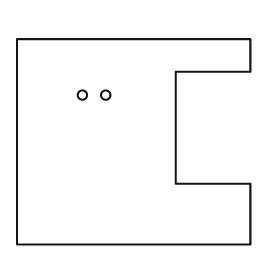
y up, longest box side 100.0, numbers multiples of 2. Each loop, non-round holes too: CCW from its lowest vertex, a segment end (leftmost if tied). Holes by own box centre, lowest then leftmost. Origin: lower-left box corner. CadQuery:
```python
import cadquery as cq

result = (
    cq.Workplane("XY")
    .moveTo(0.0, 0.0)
    .lineTo(100.0, 0.0)
    .lineTo(100.0, 26.0)
    .lineTo(68.0, 26.0)
    .lineTo(68.0, 74.0)
    .lineTo(100.0, 74.0)
    .lineTo(100.0, 88.0)
    .lineTo(0.0, 88.0)
    .close()
    .moveTo(28.0, 64.0)
    .circle(2.0)
    .moveTo(38.0, 64.0)
    .circle(2.0)
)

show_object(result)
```